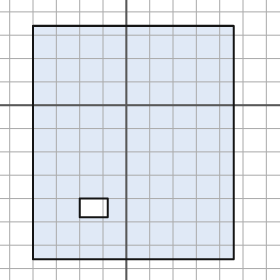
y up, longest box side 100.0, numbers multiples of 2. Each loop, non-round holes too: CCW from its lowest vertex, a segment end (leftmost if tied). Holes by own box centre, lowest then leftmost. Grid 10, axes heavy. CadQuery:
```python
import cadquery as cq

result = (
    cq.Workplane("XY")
    .moveTo(-40.0, -66.0)
    .lineTo(46.0, -66.0)
    .lineTo(46.0, 34.0)
    .lineTo(-40.0, 34.0)
    .close()
    .moveTo(-20.0, -48.0)
    .lineTo(-8.0, -48.0)
    .lineTo(-8.0, -40.0)
    .lineTo(-20.0, -40.0)
    .close()
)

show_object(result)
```